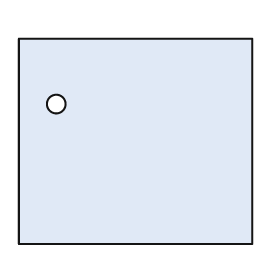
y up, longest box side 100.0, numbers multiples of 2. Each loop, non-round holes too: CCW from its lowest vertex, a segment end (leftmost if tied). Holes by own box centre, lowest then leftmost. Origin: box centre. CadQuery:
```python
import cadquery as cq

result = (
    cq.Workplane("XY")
    .moveTo(-50.0, -44.0)
    .lineTo(50.0, -44.0)
    .lineTo(50.0, 44.0)
    .lineTo(-50.0, 44.0)
    .close()
    .moveTo(-34.0, 16.0)
    .circle(4.0)
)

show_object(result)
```